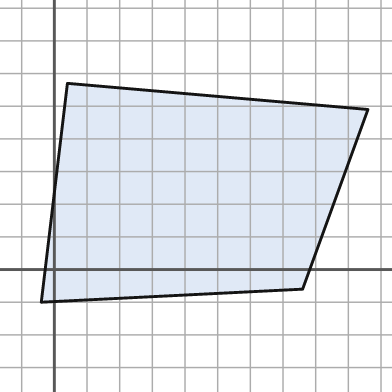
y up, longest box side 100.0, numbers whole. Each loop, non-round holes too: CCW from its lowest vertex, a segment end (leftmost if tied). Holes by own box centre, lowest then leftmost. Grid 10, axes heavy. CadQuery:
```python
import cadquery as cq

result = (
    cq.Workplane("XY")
    .moveTo(-4.0, -10.0)
    .lineTo(76.0, -6.0)
    .lineTo(96.0, 49.0)
    .lineTo(4.0, 57.0)
    .close()
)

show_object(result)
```